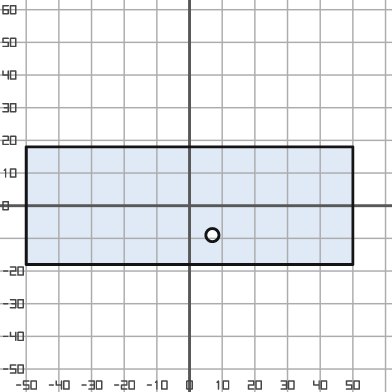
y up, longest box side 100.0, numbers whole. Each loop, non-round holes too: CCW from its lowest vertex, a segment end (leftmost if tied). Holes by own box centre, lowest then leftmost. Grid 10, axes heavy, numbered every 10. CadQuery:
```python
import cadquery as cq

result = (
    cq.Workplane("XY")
    .moveTo(-50.0, -18.0)
    .lineTo(50.0, -18.0)
    .lineTo(50.0, 18.0)
    .lineTo(-50.0, 18.0)
    .close()
    .moveTo(7.0, -9.0)
    .circle(2.0)
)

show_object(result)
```